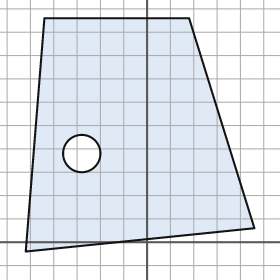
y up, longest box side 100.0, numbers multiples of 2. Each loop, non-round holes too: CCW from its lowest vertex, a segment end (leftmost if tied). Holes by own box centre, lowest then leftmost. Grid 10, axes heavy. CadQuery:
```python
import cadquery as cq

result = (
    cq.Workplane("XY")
    .moveTo(-52.0, -4.0)
    .lineTo(46.0, 6.0)
    .lineTo(18.0, 96.0)
    .lineTo(-44.0, 96.0)
    .close()
    .moveTo(-28.0, 38.0)
    .circle(8.0)
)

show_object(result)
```